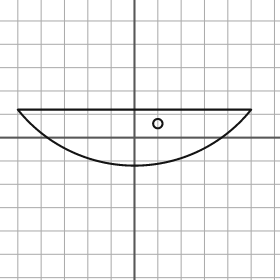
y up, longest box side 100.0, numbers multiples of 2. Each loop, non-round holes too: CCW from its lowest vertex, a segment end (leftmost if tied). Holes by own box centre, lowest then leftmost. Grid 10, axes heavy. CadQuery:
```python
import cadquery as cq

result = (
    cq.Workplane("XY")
    .moveTo(-50.0, 12.0)
    .threePointArc((0.0, -12.0), (50.0, 12.0))
    .close()
    .moveTo(10.0, 6.0)
    .circle(2.0)
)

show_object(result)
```